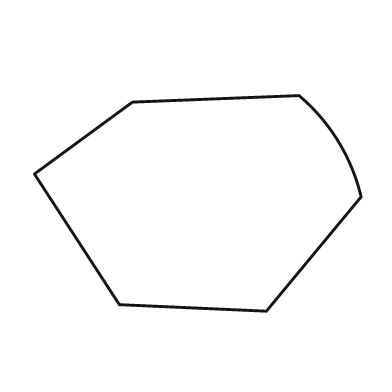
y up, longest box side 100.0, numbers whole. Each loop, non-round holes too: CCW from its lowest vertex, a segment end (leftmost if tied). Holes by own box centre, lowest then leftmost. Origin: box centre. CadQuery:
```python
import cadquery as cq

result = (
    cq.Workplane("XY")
    .moveTo(21.0, -33.0)
    .lineTo(50.0, 2.0)
    .threePointArc((43.0, 19.0), (31.0, 33.0))
    .lineTo(-20.0, 31.0)
    .lineTo(-50.0, 9.0)
    .lineTo(-24.0, -31.0)
    .close()
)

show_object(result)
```